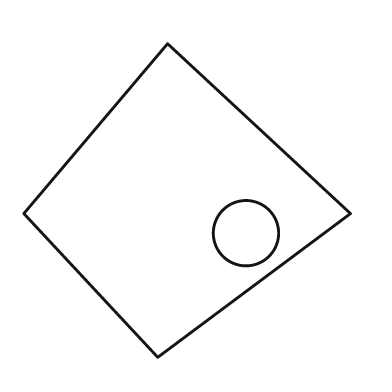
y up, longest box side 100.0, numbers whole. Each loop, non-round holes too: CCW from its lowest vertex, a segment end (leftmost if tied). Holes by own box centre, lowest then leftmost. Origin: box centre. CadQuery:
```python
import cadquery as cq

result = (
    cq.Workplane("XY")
    .moveTo(-9.0, -48.0)
    .lineTo(50.0, -4.0)
    .lineTo(-6.0, 48.0)
    .lineTo(-50.0, -4.0)
    .close()
    .moveTo(18.0, -10.0)
    .circle(10.0)
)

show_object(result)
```